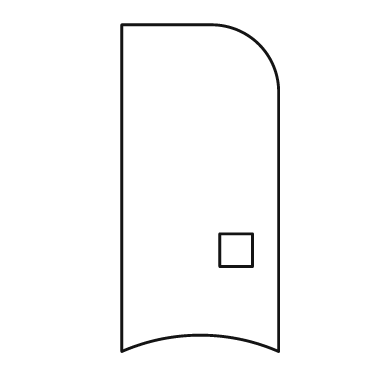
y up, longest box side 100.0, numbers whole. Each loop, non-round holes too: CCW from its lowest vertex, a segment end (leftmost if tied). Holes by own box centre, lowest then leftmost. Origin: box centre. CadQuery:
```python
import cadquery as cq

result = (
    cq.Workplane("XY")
    .moveTo(-24.0, -50.0)
    .threePointArc((0.0, -45.0), (24.0, -50.0))
    .lineTo(24.0, 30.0)
    .threePointArc((18.0, 44.0), (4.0, 50.0))
    .lineTo(-24.0, 50.0)
    .close()
    .moveTo(6.0, -24.0)
    .lineTo(16.0, -24.0)
    .lineTo(16.0, -14.0)
    .lineTo(6.0, -14.0)
    .close()
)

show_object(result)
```